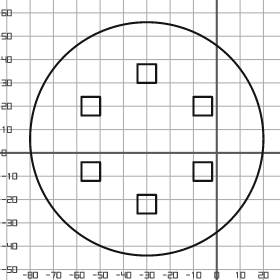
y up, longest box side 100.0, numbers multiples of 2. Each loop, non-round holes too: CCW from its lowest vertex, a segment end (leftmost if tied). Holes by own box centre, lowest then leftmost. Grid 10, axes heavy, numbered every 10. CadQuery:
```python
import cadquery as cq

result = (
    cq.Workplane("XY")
    .moveTo(-30.0, 6.0)
    .circle(50.0)
    .moveTo(-34.0, -26.0)
    .lineTo(-26.0, -26.0)
    .lineTo(-26.0, -18.0)
    .lineTo(-34.0, -18.0)
    .close()
    .moveTo(-58.0, -12.0)
    .lineTo(-50.0, -12.0)
    .lineTo(-50.0, -4.0)
    .lineTo(-58.0, -4.0)
    .close()
    .moveTo(-10.0, -12.0)
    .lineTo(-2.0, -12.0)
    .lineTo(-2.0, -4.0)
    .lineTo(-10.0, -4.0)
    .close()
    .moveTo(-58.0, 16.0)
    .lineTo(-50.0, 16.0)
    .lineTo(-50.0, 24.0)
    .lineTo(-58.0, 24.0)
    .close()
    .moveTo(-10.0, 16.0)
    .lineTo(-2.0, 16.0)
    .lineTo(-2.0, 24.0)
    .lineTo(-10.0, 24.0)
    .close()
    .moveTo(-34.0, 30.0)
    .lineTo(-26.0, 30.0)
    .lineTo(-26.0, 38.0)
    .lineTo(-34.0, 38.0)
    .close()
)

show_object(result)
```